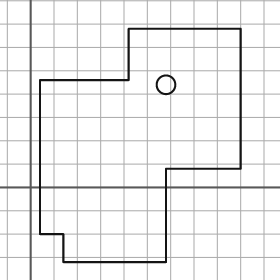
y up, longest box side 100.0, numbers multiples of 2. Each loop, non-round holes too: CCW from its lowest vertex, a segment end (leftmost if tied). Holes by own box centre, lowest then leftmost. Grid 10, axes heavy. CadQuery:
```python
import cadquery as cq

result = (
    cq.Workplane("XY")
    .moveTo(14.0, -32.0)
    .lineTo(58.0, -32.0)
    .lineTo(58.0, 8.0)
    .lineTo(90.0, 8.0)
    .lineTo(90.0, 68.0)
    .lineTo(42.0, 68.0)
    .lineTo(42.0, 46.0)
    .lineTo(4.0, 46.0)
    .lineTo(4.0, -20.0)
    .lineTo(14.0, -20.0)
    .close()
    .moveTo(58.0, 44.0)
    .circle(4.0)
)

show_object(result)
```